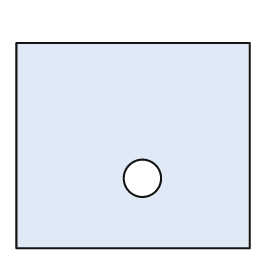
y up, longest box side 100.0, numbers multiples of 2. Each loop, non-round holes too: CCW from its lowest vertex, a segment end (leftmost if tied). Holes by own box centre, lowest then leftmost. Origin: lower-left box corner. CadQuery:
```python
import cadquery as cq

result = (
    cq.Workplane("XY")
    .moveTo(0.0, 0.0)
    .lineTo(100.0, 0.0)
    .lineTo(100.0, 88.0)
    .lineTo(0.0, 88.0)
    .close()
    .moveTo(54.0, 30.0)
    .circle(8.0)
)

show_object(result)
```